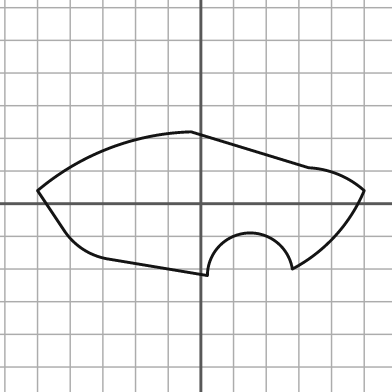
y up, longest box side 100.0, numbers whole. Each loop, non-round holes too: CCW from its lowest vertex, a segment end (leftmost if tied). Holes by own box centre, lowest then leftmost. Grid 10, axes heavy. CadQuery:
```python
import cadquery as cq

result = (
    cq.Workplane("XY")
    .moveTo(2.0, -22.0)
    .threePointArc((14.0, -9.0), (28.0, -20.0))
    .threePointArc((41.0, -10.0), (50.0, 4.0))
    .threePointArc((42.0, 9.0), (33.0, 11.0))
    .lineTo(-3.0, 22.0)
    .threePointArc((-28.0, 17.0), (-50.0, 4.0))
    .lineTo(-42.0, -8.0)
    .threePointArc((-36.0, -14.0), (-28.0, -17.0))
    .close()
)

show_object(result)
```